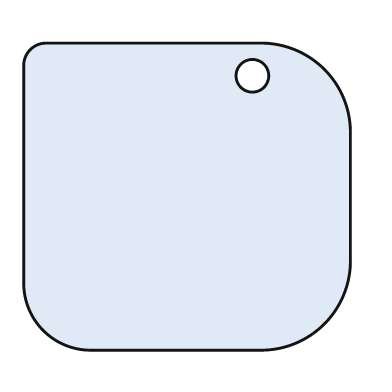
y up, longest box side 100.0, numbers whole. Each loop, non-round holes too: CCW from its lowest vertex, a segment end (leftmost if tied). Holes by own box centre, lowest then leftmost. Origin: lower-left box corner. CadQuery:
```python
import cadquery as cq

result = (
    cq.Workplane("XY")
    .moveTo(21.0, 0.0)
    .lineTo(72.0, 0.0)
    .threePointArc((92.0, 8.0), (100.0, 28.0))
    .lineTo(100.0, 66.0)
    .threePointArc((92.0, 86.0), (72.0, 94.0))
    .lineTo(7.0, 94.0)
    .threePointArc((2.0, 92.0), (0.0, 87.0))
    .lineTo(0.0, 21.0)
    .threePointArc((6.0, 6.0), (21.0, 0.0))
    .close()
    .moveTo(70.0, 84.0)
    .circle(5.0)
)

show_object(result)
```